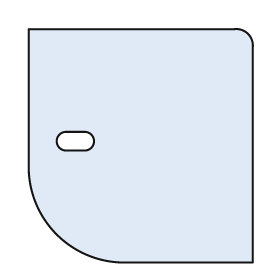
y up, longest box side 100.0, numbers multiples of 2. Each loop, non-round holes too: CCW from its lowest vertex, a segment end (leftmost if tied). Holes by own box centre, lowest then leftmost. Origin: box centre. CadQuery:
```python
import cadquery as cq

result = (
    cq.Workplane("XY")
    .moveTo(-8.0, -50.0)
    .lineTo(48.0, -50.0)
    .lineTo(48.0, 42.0)
    .threePointArc((46.0, 48.0), (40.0, 50.0))
    .lineTo(-48.0, 50.0)
    .lineTo(-48.0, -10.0)
    .threePointArc((-36.0, -38.0), (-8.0, -50.0))
    .close()
    .moveTo(-32.0, -2.0)
    .lineTo(-24.0, -2.0)
    .threePointArc((-20.0, 2.0), (-24.0, 6.0))
    .lineTo(-32.0, 6.0)
    .threePointArc((-36.0, 2.0), (-32.0, -2.0))
    .close()
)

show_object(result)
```